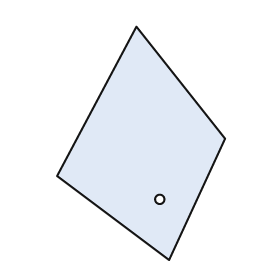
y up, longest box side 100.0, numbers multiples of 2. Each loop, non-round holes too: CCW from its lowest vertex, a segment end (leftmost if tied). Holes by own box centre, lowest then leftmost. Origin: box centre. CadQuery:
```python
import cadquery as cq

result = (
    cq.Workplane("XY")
    .moveTo(12.0, -50.0)
    .lineTo(36.0, 2.0)
    .lineTo(-2.0, 50.0)
    .lineTo(-36.0, -14.0)
    .close()
    .moveTo(8.0, -24.0)
    .circle(2.0)
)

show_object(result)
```